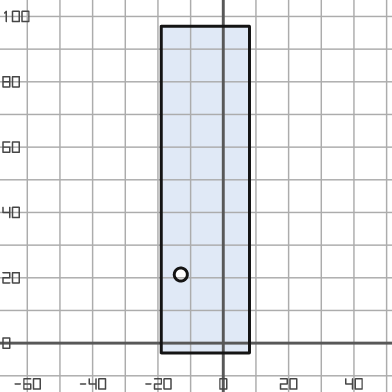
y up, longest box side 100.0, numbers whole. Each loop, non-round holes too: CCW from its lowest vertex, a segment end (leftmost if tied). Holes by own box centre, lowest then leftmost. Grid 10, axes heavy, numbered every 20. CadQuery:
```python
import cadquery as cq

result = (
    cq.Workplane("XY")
    .moveTo(-19.0, -3.0)
    .lineTo(8.0, -3.0)
    .lineTo(8.0, 97.0)
    .lineTo(-19.0, 97.0)
    .close()
    .moveTo(-13.0, 21.0)
    .circle(2.0)
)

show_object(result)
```